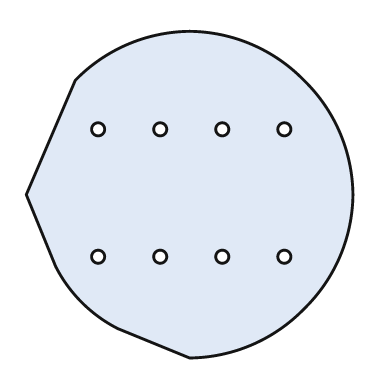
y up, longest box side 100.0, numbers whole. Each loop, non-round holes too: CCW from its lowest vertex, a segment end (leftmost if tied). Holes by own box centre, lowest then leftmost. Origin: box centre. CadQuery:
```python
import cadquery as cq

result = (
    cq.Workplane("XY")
    .moveTo(0.0, -50.0)
    .threePointArc((19.0, -46.0), (35.0, -35.0))
    .threePointArc((46.0, -19.0), (50.0, 0.0))
    .threePointArc((46.0, 19.0), (35.0, 35.0))
    .threePointArc((19.0, 46.0), (0.0, 50.0))
    .threePointArc((-19.0, 46.0), (-35.0, 35.0))
    .lineTo(-50.0, 0.0)
    .lineTo(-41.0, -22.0)
    .threePointArc((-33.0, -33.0), (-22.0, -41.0))
    .close()
    .moveTo(-28.0, -19.0)
    .circle(2.0)
    .moveTo(-9.0, -19.0)
    .circle(2.0)
    .moveTo(10.0, -19.0)
    .circle(2.0)
    .moveTo(29.0, -19.0)
    .circle(2.0)
    .moveTo(-28.0, 20.0)
    .circle(2.0)
    .moveTo(-9.0, 20.0)
    .circle(2.0)
    .moveTo(10.0, 20.0)
    .circle(2.0)
    .moveTo(29.0, 20.0)
    .circle(2.0)
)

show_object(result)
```